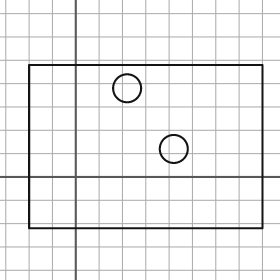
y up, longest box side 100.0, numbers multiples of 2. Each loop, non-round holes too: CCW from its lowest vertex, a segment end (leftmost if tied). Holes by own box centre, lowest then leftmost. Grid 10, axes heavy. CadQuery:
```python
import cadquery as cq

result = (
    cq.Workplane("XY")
    .moveTo(-20.0, -22.0)
    .lineTo(80.0, -22.0)
    .lineTo(80.0, 48.0)
    .lineTo(-20.0, 48.0)
    .close()
    .moveTo(42.0, 12.0)
    .circle(6.0)
    .moveTo(22.0, 38.0)
    .circle(6.0)
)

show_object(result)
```